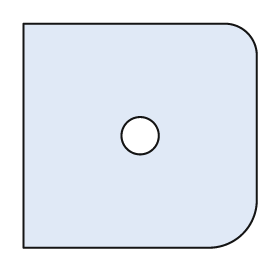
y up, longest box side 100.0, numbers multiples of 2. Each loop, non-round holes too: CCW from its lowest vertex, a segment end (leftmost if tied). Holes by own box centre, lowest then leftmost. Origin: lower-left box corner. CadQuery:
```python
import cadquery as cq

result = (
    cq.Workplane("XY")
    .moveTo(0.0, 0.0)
    .lineTo(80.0, 0.0)
    .threePointArc((94.0, 6.0), (100.0, 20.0))
    .lineTo(100.0, 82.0)
    .threePointArc((96.0, 92.0), (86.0, 96.0))
    .lineTo(0.0, 96.0)
    .close()
    .moveTo(50.0, 48.0)
    .circle(8.0)
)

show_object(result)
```